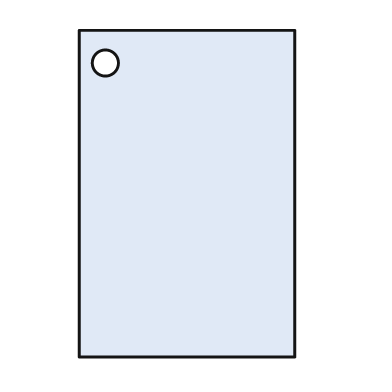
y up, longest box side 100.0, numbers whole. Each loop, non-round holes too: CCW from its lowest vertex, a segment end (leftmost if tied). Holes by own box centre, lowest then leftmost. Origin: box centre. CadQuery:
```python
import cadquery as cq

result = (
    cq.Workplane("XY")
    .moveTo(-33.0, -50.0)
    .lineTo(33.0, -50.0)
    .lineTo(33.0, 50.0)
    .lineTo(-33.0, 50.0)
    .close()
    .moveTo(-25.0, 40.0)
    .circle(4.0)
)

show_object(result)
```